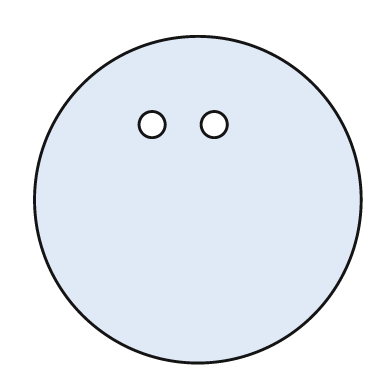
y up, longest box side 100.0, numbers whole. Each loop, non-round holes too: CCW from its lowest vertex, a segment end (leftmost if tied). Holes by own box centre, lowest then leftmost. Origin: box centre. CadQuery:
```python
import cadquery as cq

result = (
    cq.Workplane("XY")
    .moveTo(0.0, 0.0)
    .circle(50.0)
    .moveTo(-14.0, 23.0)
    .circle(4.0)
    .moveTo(5.0, 23.0)
    .circle(4.0)
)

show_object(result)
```